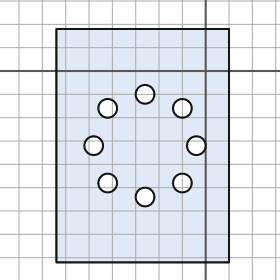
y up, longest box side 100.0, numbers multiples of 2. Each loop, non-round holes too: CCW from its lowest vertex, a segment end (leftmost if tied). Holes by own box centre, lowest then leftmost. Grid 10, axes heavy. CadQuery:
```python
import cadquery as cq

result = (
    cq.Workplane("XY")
    .moveTo(-64.0, -82.0)
    .lineTo(10.0, -82.0)
    .lineTo(10.0, 18.0)
    .lineTo(-64.0, 18.0)
    .close()
    .moveTo(-26.0, -54.0)
    .circle(4.0)
    .moveTo(-42.0, -48.0)
    .circle(4.0)
    .moveTo(-10.0, -48.0)
    .circle(4.0)
    .moveTo(-48.0, -32.0)
    .circle(4.0)
    .moveTo(-4.0, -32.0)
    .circle(4.0)
    .moveTo(-42.0, -16.0)
    .circle(4.0)
    .moveTo(-10.0, -16.0)
    .circle(4.0)
    .moveTo(-26.0, -10.0)
    .circle(4.0)
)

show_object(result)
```